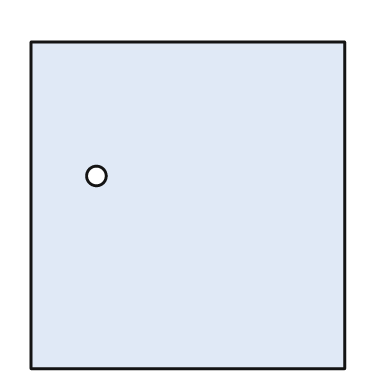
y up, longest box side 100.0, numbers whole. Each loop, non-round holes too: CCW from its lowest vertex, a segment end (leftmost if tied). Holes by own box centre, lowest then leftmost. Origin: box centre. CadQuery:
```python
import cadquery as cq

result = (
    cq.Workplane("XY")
    .moveTo(-48.0, -50.0)
    .lineTo(48.0, -50.0)
    .lineTo(48.0, 50.0)
    .lineTo(-48.0, 50.0)
    .close()
    .moveTo(-28.0, 9.0)
    .circle(3.0)
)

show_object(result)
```